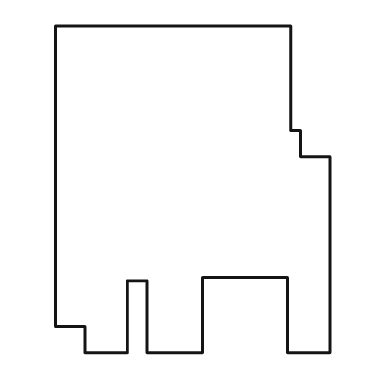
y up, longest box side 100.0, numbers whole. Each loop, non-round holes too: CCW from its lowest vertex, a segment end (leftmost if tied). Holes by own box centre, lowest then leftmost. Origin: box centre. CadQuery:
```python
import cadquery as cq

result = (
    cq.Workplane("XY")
    .moveTo(-33.0, -50.0)
    .lineTo(-20.0, -50.0)
    .lineTo(-20.0, -28.0)
    .lineTo(-14.0, -28.0)
    .lineTo(-14.0, -50.0)
    .lineTo(3.0, -50.0)
    .lineTo(3.0, -27.0)
    .lineTo(29.0, -27.0)
    .lineTo(29.0, -50.0)
    .lineTo(42.0, -50.0)
    .lineTo(42.0, 10.0)
    .lineTo(33.0, 10.0)
    .lineTo(33.0, 18.0)
    .lineTo(30.0, 18.0)
    .lineTo(30.0, 50.0)
    .lineTo(-42.0, 50.0)
    .lineTo(-42.0, -42.0)
    .lineTo(-33.0, -42.0)
    .close()
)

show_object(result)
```